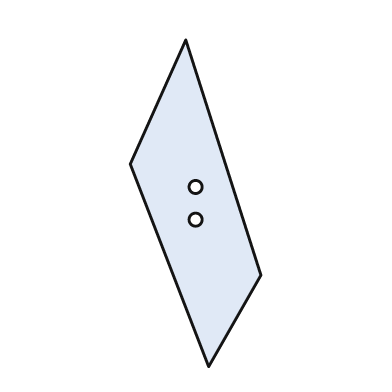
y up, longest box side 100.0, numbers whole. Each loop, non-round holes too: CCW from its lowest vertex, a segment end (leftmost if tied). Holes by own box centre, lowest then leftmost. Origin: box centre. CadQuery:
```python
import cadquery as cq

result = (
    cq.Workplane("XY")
    .moveTo(4.0, -50.0)
    .lineTo(20.0, -22.0)
    .lineTo(-3.0, 50.0)
    .lineTo(-20.0, 12.0)
    .close()
    .moveTo(0.0, -5.0)
    .circle(2.0)
    .moveTo(0.0, 5.0)
    .circle(2.0)
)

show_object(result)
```